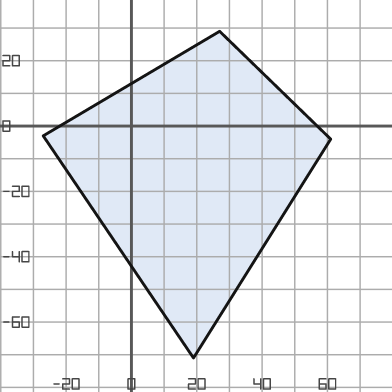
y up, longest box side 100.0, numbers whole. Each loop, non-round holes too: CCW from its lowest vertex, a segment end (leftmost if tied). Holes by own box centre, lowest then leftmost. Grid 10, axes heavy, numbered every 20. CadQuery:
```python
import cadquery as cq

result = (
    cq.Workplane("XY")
    .moveTo(19.0, -71.0)
    .lineTo(61.0, -4.0)
    .lineTo(27.0, 29.0)
    .lineTo(-27.0, -3.0)
    .close()
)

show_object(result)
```